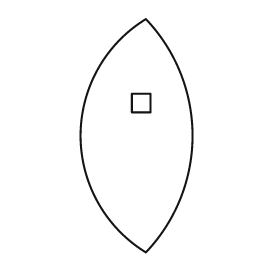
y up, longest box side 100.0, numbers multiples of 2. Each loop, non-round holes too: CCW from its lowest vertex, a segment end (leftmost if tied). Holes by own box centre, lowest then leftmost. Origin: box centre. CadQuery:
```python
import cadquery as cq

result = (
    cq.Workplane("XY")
    .moveTo(4.0, -50.0)
    .threePointArc((24.0, 0.0), (4.0, 50.0))
    .threePointArc((-24.0, 0.0), (4.0, -50.0))
    .close()
    .moveTo(-2.0, 10.0)
    .lineTo(6.0, 10.0)
    .lineTo(6.0, 18.0)
    .lineTo(-2.0, 18.0)
    .close()
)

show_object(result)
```